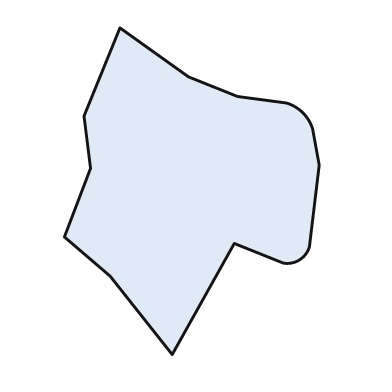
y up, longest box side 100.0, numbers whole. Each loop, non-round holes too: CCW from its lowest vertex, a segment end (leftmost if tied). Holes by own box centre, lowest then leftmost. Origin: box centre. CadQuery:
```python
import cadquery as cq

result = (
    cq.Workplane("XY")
    .moveTo(-6.0, -50.0)
    .lineTo(13.0, -16.0)
    .lineTo(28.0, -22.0)
    .threePointArc((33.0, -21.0), (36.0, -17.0))
    .lineTo(39.0, 8.0)
    .lineTo(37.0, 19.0)
    .threePointArc((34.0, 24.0), (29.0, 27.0))
    .lineTo(14.0, 29.0)
    .lineTo(-1.0, 35.0)
    .lineTo(-22.0, 50.0)
    .lineTo(-33.0, 23.0)
    .lineTo(-31.0, 7.0)
    .lineTo(-39.0, -14.0)
    .lineTo(-25.0, -26.0)
    .close()
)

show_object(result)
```